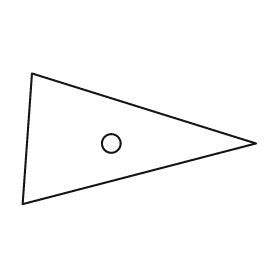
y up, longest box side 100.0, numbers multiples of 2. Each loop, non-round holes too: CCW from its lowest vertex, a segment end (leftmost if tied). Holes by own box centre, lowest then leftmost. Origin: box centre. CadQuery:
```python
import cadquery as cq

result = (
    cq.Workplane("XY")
    .moveTo(-50.0, -28.0)
    .lineTo(50.0, -2.0)
    .lineTo(-46.0, 28.0)
    .close()
    .moveTo(-12.0, -2.0)
    .circle(4.0)
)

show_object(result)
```